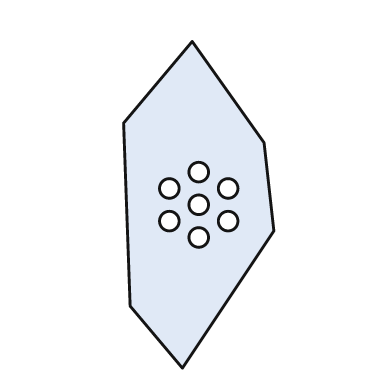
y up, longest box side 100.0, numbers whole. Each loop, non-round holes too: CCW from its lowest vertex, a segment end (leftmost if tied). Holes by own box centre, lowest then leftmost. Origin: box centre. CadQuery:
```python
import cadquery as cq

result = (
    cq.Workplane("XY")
    .moveTo(-5.0, -50.0)
    .lineTo(23.0, -8.0)
    .lineTo(20.0, 19.0)
    .lineTo(-2.0, 50.0)
    .lineTo(-23.0, 25.0)
    .lineTo(-21.0, -31.0)
    .close()
    .moveTo(0.0, -10.0)
    .circle(3.0)
    .moveTo(-9.0, -5.0)
    .circle(3.0)
    .moveTo(9.0, -5.0)
    .circle(3.0)
    .moveTo(0.0, 0.0)
    .circle(3.0)
    .moveTo(-9.0, 5.0)
    .circle(3.0)
    .moveTo(9.0, 5.0)
    .circle(3.0)
    .moveTo(0.0, 10.0)
    .circle(3.0)
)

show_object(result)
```